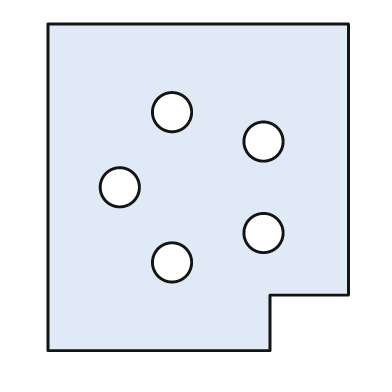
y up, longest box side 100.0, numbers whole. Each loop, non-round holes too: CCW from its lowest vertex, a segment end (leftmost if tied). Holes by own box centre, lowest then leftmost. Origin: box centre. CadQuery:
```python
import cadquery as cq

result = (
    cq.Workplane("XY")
    .moveTo(-46.0, -50.0)
    .lineTo(22.0, -50.0)
    .lineTo(22.0, -33.0)
    .lineTo(46.0, -33.0)
    .lineTo(46.0, 50.0)
    .lineTo(-46.0, 50.0)
    .close()
    .moveTo(-8.0, -23.0)
    .circle(6.0)
    .moveTo(20.0, -14.0)
    .circle(6.0)
    .moveTo(-24.0, 0.0)
    .circle(6.0)
    .moveTo(20.0, 14.0)
    .circle(6.0)
    .moveTo(-8.0, 23.0)
    .circle(6.0)
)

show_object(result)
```